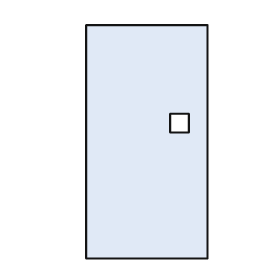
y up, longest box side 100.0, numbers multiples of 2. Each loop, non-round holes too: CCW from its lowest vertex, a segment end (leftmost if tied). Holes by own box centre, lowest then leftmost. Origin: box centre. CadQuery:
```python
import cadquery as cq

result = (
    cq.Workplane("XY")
    .moveTo(-26.0, -50.0)
    .lineTo(26.0, -50.0)
    .lineTo(26.0, 50.0)
    .lineTo(-26.0, 50.0)
    .close()
    .moveTo(10.0, 4.0)
    .lineTo(18.0, 4.0)
    .lineTo(18.0, 12.0)
    .lineTo(10.0, 12.0)
    .close()
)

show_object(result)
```